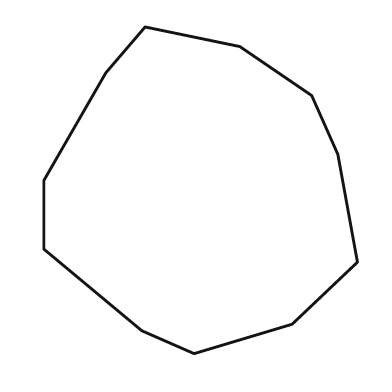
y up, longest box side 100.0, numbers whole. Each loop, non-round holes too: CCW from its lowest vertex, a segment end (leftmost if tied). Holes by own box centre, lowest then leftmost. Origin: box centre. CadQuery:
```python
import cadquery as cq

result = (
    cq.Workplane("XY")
    .moveTo(-2.0, -50.0)
    .lineTo(28.0, -41.0)
    .lineTo(48.0, -22.0)
    .lineTo(42.0, 11.0)
    .lineTo(34.0, 29.0)
    .lineTo(12.0, 44.0)
    .lineTo(-17.0, 50.0)
    .lineTo(-29.0, 36.0)
    .lineTo(-48.0, 3.0)
    .lineTo(-48.0, -18.0)
    .lineTo(-18.0, -43.0)
    .close()
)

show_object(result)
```